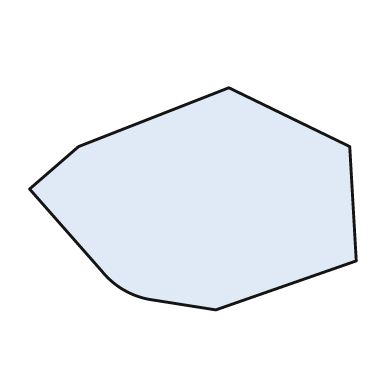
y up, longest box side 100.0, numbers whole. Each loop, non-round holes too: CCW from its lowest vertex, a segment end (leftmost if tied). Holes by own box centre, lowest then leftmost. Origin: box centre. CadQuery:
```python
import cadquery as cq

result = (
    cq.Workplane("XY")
    .moveTo(7.0, -34.0)
    .lineTo(50.0, -19.0)
    .lineTo(48.0, 16.0)
    .lineTo(11.0, 34.0)
    .lineTo(-35.0, 16.0)
    .lineTo(-50.0, 3.0)
    .lineTo(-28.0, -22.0)
    .threePointArc((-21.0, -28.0), (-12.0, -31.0))
    .close()
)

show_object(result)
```